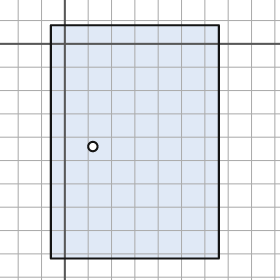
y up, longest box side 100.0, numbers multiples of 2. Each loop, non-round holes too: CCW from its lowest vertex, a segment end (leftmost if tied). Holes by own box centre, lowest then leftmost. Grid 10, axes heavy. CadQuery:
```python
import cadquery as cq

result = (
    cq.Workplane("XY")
    .moveTo(-6.0, -92.0)
    .lineTo(66.0, -92.0)
    .lineTo(66.0, 8.0)
    .lineTo(-6.0, 8.0)
    .close()
    .moveTo(12.0, -44.0)
    .circle(2.0)
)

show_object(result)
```